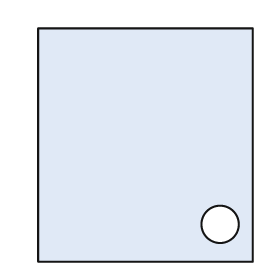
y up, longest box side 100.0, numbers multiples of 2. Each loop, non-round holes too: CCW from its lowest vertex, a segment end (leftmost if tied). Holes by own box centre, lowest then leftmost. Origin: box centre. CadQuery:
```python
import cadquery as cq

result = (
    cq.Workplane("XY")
    .moveTo(-46.0, -50.0)
    .lineTo(46.0, -50.0)
    .lineTo(46.0, 50.0)
    .lineTo(-46.0, 50.0)
    .close()
    .moveTo(32.0, -34.0)
    .circle(8.0)
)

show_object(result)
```